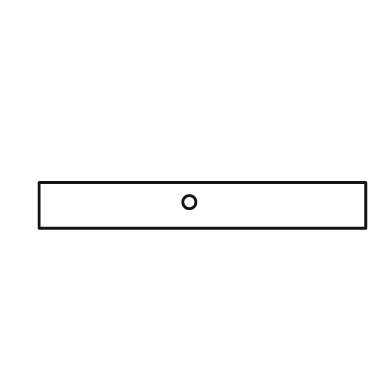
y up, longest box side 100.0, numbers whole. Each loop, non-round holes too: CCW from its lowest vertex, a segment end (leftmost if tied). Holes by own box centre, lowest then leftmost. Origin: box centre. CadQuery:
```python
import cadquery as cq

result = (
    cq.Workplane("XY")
    .moveTo(-50.0, -7.0)
    .lineTo(50.0, -7.0)
    .lineTo(50.0, 7.0)
    .lineTo(-50.0, 7.0)
    .close()
    .moveTo(-4.0, 1.0)
    .circle(2.0)
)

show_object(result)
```